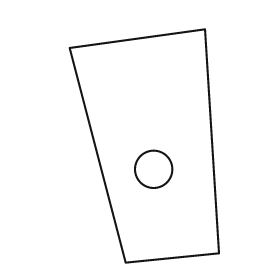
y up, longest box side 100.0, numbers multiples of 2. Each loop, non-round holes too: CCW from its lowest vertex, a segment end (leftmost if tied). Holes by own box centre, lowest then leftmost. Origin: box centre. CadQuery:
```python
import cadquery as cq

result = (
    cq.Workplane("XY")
    .moveTo(-8.0, -50.0)
    .lineTo(32.0, -46.0)
    .lineTo(26.0, 50.0)
    .lineTo(-32.0, 42.0)
    .close()
    .moveTo(4.0, -10.0)
    .circle(8.0)
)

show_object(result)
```